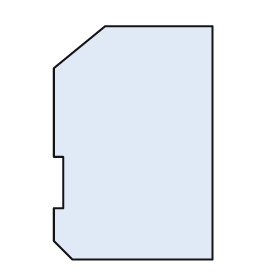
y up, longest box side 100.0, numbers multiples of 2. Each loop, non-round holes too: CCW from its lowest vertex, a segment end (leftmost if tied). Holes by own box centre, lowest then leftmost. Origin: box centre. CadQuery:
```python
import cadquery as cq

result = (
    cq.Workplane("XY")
    .moveTo(-26.0, -50.0)
    .lineTo(34.0, -50.0)
    .lineTo(34.0, 50.0)
    .lineTo(-12.0, 50.0)
    .lineTo(-34.0, 32.0)
    .lineTo(-34.0, -6.0)
    .lineTo(-30.0, -6.0)
    .lineTo(-30.0, -28.0)
    .lineTo(-34.0, -28.0)
    .lineTo(-34.0, -42.0)
    .close()
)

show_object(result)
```